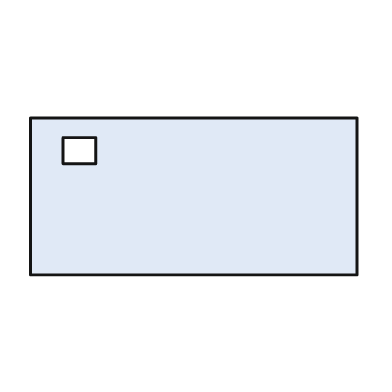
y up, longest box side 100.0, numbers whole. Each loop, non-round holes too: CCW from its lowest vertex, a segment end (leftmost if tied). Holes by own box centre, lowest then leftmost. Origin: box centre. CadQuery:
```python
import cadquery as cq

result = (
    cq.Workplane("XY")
    .moveTo(-50.0, -24.0)
    .lineTo(50.0, -24.0)
    .lineTo(50.0, 24.0)
    .lineTo(-50.0, 24.0)
    .close()
    .moveTo(-40.0, 10.0)
    .lineTo(-30.0, 10.0)
    .lineTo(-30.0, 18.0)
    .lineTo(-40.0, 18.0)
    .close()
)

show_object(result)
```